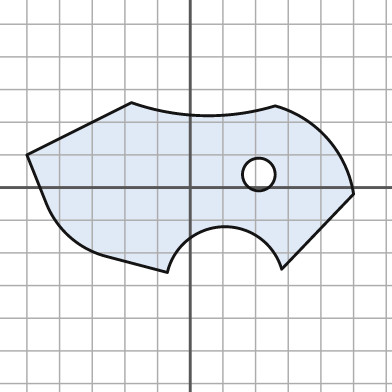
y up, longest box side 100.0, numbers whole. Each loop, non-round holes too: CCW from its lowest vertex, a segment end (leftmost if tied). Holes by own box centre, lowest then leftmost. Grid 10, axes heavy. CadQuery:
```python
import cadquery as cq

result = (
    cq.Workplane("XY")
    .moveTo(-7.0, -26.0)
    .threePointArc((10.0, -12.0), (28.0, -25.0))
    .lineTo(50.0, -2.0)
    .threePointArc((42.0, 15.0), (26.0, 25.0))
    .threePointArc((4.0, 22.0), (-18.0, 26.0))
    .lineTo(-50.0, 10.0)
    .lineTo(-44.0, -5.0)
    .threePointArc((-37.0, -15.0), (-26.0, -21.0))
    .close()
    .moveTo(21.0, 4.0)
    .circle(5.0)
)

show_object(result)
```